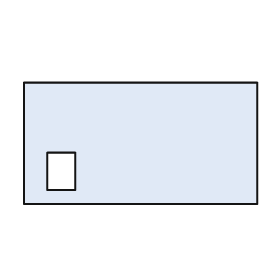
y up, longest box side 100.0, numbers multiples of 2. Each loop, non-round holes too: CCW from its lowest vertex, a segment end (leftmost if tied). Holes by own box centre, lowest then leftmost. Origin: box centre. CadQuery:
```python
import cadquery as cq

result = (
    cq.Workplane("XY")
    .moveTo(-50.0, -26.0)
    .lineTo(50.0, -26.0)
    .lineTo(50.0, 26.0)
    .lineTo(-50.0, 26.0)
    .close()
    .moveTo(-40.0, -20.0)
    .lineTo(-28.0, -20.0)
    .lineTo(-28.0, -4.0)
    .lineTo(-40.0, -4.0)
    .close()
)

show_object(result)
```